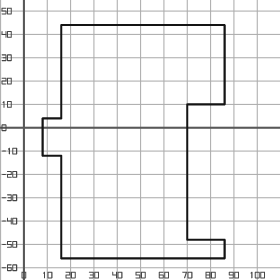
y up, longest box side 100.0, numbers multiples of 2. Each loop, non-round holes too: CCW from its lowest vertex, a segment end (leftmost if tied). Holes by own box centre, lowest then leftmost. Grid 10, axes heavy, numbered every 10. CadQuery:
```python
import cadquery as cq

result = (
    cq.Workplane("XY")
    .moveTo(16.0, -56.0)
    .lineTo(86.0, -56.0)
    .lineTo(86.0, -48.0)
    .lineTo(70.0, -48.0)
    .lineTo(70.0, 10.0)
    .lineTo(86.0, 10.0)
    .lineTo(86.0, 44.0)
    .lineTo(16.0, 44.0)
    .lineTo(16.0, 4.0)
    .lineTo(8.0, 4.0)
    .lineTo(8.0, -12.0)
    .lineTo(16.0, -12.0)
    .close()
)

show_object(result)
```